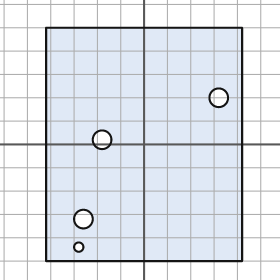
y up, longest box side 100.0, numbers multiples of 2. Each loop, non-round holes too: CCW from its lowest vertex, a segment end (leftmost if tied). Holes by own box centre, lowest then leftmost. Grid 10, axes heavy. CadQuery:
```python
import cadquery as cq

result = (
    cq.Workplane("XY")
    .moveTo(-42.0, -50.0)
    .lineTo(42.0, -50.0)
    .lineTo(42.0, 50.0)
    .lineTo(-42.0, 50.0)
    .close()
    .moveTo(-28.0, -44.0)
    .circle(2.0)
    .moveTo(-26.0, -32.0)
    .circle(4.0)
    .moveTo(-18.0, 2.0)
    .circle(4.0)
    .moveTo(32.0, 20.0)
    .circle(4.0)
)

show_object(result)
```